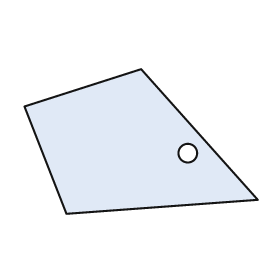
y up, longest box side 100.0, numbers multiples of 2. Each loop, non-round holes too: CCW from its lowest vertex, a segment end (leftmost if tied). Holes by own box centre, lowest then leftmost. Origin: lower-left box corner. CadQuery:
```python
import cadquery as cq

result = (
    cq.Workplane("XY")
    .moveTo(18.0, 0.0)
    .lineTo(100.0, 6.0)
    .lineTo(50.0, 62.0)
    .lineTo(0.0, 46.0)
    .close()
    .moveTo(70.0, 26.0)
    .circle(4.0)
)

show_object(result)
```